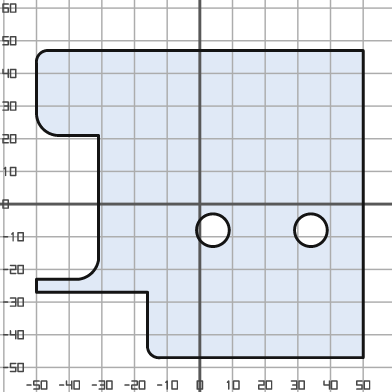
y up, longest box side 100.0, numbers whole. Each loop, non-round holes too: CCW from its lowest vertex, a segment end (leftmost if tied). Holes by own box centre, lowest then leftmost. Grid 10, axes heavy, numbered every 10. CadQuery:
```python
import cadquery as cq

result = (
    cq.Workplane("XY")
    .moveTo(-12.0, -47.0)
    .lineTo(50.0, -47.0)
    .lineTo(50.0, 47.0)
    .lineTo(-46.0, 47.0)
    .threePointArc((-49.0, 46.0), (-50.0, 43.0))
    .lineTo(-50.0, 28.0)
    .threePointArc((-48.0, 23.0), (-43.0, 21.0))
    .lineTo(-31.0, 21.0)
    .lineTo(-31.0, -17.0)
    .threePointArc((-33.0, -21.0), (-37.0, -23.0))
    .lineTo(-50.0, -23.0)
    .lineTo(-50.0, -27.0)
    .lineTo(-16.0, -27.0)
    .lineTo(-16.0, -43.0)
    .threePointArc((-15.0, -46.0), (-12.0, -47.0))
    .close()
    .moveTo(4.0, -8.0)
    .circle(5.0)
    .moveTo(34.0, -8.0)
    .circle(5.0)
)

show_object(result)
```